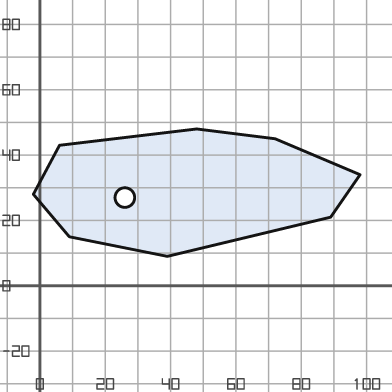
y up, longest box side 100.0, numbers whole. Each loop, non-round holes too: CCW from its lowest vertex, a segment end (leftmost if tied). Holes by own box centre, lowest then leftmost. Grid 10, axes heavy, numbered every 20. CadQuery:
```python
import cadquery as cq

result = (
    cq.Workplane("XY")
    .moveTo(39.0, 9.0)
    .lineTo(89.0, 21.0)
    .lineTo(98.0, 34.0)
    .lineTo(72.0, 45.0)
    .lineTo(48.0, 48.0)
    .lineTo(6.0, 43.0)
    .lineTo(-2.0, 28.0)
    .lineTo(9.0, 15.0)
    .close()
    .moveTo(26.0, 27.0)
    .circle(3.0)
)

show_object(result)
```